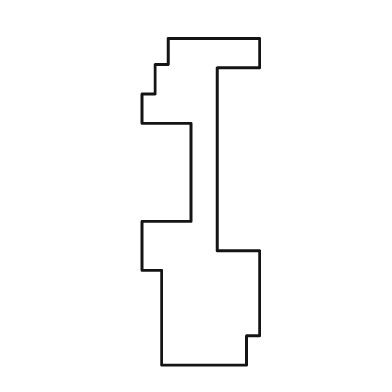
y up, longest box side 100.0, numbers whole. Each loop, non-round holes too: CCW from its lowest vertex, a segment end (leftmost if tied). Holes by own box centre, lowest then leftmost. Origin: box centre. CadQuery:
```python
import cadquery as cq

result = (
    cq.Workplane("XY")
    .moveTo(-12.0, -50.0)
    .lineTo(14.0, -50.0)
    .lineTo(14.0, -41.0)
    .lineTo(18.0, -41.0)
    .lineTo(18.0, -15.0)
    .lineTo(5.0, -15.0)
    .lineTo(5.0, 41.0)
    .lineTo(18.0, 41.0)
    .lineTo(18.0, 50.0)
    .lineTo(-10.0, 50.0)
    .lineTo(-10.0, 42.0)
    .lineTo(-14.0, 42.0)
    .lineTo(-14.0, 33.0)
    .lineTo(-18.0, 33.0)
    .lineTo(-18.0, 24.0)
    .lineTo(-3.0, 24.0)
    .lineTo(-3.0, -6.0)
    .lineTo(-18.0, -6.0)
    .lineTo(-18.0, -21.0)
    .lineTo(-12.0, -21.0)
    .close()
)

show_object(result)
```